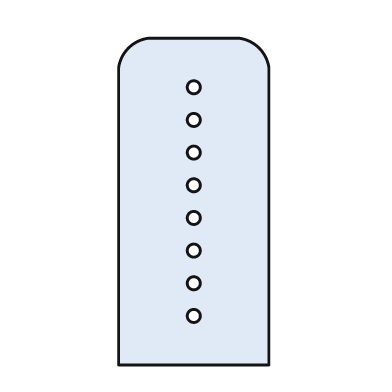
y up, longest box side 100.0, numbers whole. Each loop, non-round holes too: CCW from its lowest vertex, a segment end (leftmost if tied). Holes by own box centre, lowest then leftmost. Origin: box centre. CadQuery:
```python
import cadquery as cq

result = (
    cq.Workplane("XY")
    .moveTo(-23.0, -50.0)
    .lineTo(23.0, -50.0)
    .lineTo(23.0, 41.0)
    .threePointArc((20.0, 47.0), (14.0, 50.0))
    .lineTo(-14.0, 50.0)
    .threePointArc((-20.0, 47.0), (-23.0, 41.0))
    .close()
    .moveTo(0.0, -35.0)
    .circle(2.0)
    .moveTo(0.0, -25.0)
    .circle(2.0)
    .moveTo(0.0, -15.0)
    .circle(2.0)
    .moveTo(0.0, -5.0)
    .circle(2.0)
    .moveTo(0.0, 5.0)
    .circle(2.0)
    .moveTo(0.0, 15.0)
    .circle(2.0)
    .moveTo(0.0, 25.0)
    .circle(2.0)
    .moveTo(0.0, 35.0)
    .circle(2.0)
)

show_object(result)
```